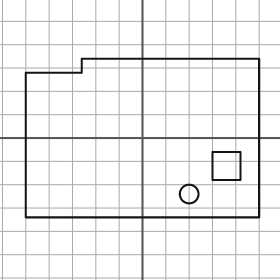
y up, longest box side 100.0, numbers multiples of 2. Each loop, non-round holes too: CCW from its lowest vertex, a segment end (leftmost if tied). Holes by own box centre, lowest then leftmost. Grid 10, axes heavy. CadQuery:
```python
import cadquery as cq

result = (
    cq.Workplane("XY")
    .moveTo(-50.0, -34.0)
    .lineTo(50.0, -34.0)
    .lineTo(50.0, 34.0)
    .lineTo(-26.0, 34.0)
    .lineTo(-26.0, 28.0)
    .lineTo(-50.0, 28.0)
    .close()
    .moveTo(20.0, -24.0)
    .circle(4.0)
    .moveTo(30.0, -18.0)
    .lineTo(42.0, -18.0)
    .lineTo(42.0, -6.0)
    .lineTo(30.0, -6.0)
    .close()
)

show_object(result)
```